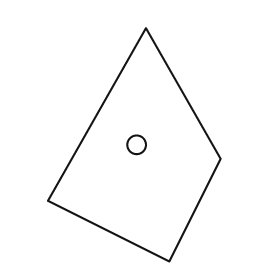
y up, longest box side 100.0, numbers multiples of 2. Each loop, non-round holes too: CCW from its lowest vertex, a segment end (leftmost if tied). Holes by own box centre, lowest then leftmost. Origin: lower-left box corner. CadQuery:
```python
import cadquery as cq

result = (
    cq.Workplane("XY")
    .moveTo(52.0, 0.0)
    .lineTo(74.0, 44.0)
    .lineTo(42.0, 100.0)
    .lineTo(0.0, 26.0)
    .close()
    .moveTo(38.0, 50.0)
    .circle(4.0)
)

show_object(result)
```